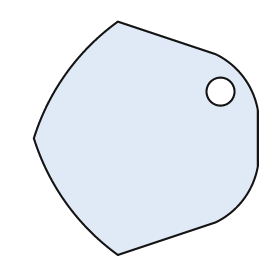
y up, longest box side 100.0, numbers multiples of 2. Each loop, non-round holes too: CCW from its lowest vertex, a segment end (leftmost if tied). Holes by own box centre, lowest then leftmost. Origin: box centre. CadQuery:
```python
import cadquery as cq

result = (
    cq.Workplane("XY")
    .moveTo(-12.0, -50.0)
    .lineTo(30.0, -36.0)
    .threePointArc((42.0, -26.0), (48.0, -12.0))
    .lineTo(48.0, 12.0)
    .threePointArc((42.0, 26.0), (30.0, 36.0))
    .lineTo(-12.0, 50.0)
    .threePointArc((-34.0, 28.0), (-48.0, 0.0))
    .threePointArc((-34.0, -28.0), (-12.0, -50.0))
    .close()
    .moveTo(32.0, 20.0)
    .circle(6.0)
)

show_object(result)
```